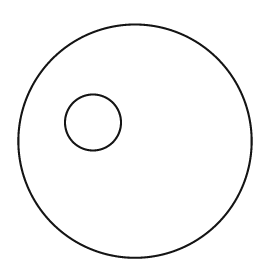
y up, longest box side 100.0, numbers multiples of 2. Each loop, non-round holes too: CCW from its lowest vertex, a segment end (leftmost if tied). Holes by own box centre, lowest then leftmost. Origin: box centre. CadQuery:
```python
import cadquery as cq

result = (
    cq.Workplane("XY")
    .moveTo(0.0, 0.0)
    .circle(50.0)
    .moveTo(-18.0, 8.0)
    .circle(12.0)
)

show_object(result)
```